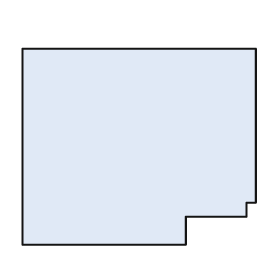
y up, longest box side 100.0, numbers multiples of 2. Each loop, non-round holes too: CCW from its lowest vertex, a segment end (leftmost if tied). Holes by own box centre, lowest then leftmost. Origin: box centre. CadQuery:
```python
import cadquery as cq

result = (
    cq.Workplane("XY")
    .moveTo(-50.0, -42.0)
    .lineTo(20.0, -42.0)
    .lineTo(20.0, -30.0)
    .lineTo(46.0, -30.0)
    .lineTo(46.0, -24.0)
    .lineTo(50.0, -24.0)
    .lineTo(50.0, 42.0)
    .lineTo(-50.0, 42.0)
    .close()
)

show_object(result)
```